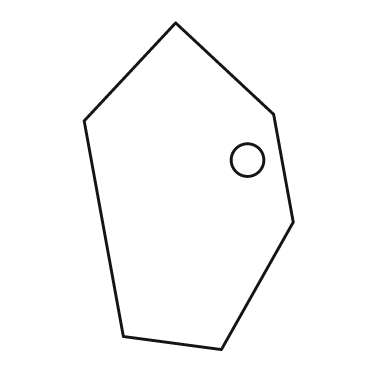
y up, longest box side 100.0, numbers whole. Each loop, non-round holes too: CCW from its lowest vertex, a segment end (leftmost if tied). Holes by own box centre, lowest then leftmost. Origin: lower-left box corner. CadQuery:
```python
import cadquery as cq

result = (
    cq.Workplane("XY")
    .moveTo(42.0, 0.0)
    .lineTo(64.0, 39.0)
    .lineTo(58.0, 72.0)
    .lineTo(28.0, 100.0)
    .lineTo(0.0, 70.0)
    .lineTo(12.0, 4.0)
    .close()
    .moveTo(50.0, 58.0)
    .circle(5.0)
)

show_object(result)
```